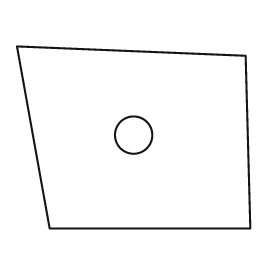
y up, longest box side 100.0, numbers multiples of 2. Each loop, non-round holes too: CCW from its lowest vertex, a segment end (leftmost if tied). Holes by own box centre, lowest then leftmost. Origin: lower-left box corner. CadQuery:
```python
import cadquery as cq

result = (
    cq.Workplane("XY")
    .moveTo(14.0, 0.0)
    .lineTo(100.0, 0.0)
    .lineTo(98.0, 74.0)
    .lineTo(0.0, 78.0)
    .close()
    .moveTo(50.0, 40.0)
    .circle(8.0)
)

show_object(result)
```